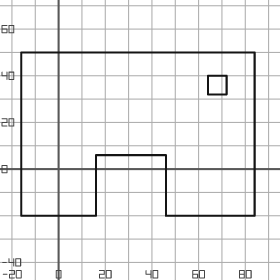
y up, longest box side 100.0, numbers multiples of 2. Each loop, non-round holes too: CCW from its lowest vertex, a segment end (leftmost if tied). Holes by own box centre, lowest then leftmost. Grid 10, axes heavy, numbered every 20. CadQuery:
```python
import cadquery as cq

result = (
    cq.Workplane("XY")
    .moveTo(-16.0, -20.0)
    .lineTo(16.0, -20.0)
    .lineTo(16.0, 6.0)
    .lineTo(46.0, 6.0)
    .lineTo(46.0, -20.0)
    .lineTo(84.0, -20.0)
    .lineTo(84.0, 50.0)
    .lineTo(-16.0, 50.0)
    .close()
    .moveTo(64.0, 32.0)
    .lineTo(72.0, 32.0)
    .lineTo(72.0, 40.0)
    .lineTo(64.0, 40.0)
    .close()
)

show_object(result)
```